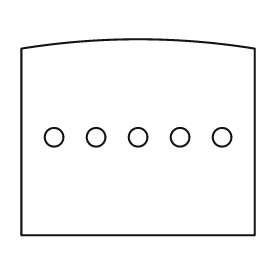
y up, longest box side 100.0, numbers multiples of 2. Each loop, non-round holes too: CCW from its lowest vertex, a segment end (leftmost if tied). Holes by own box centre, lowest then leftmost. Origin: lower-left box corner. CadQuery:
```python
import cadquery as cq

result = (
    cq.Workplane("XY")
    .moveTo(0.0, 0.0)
    .lineTo(100.0, 0.0)
    .lineTo(100.0, 80.0)
    .threePointArc((50.0, 84.0), (0.0, 80.0))
    .close()
    .moveTo(14.0, 42.0)
    .circle(4.0)
    .moveTo(32.0, 42.0)
    .circle(4.0)
    .moveTo(50.0, 42.0)
    .circle(4.0)
    .moveTo(68.0, 42.0)
    .circle(4.0)
    .moveTo(86.0, 42.0)
    .circle(4.0)
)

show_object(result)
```